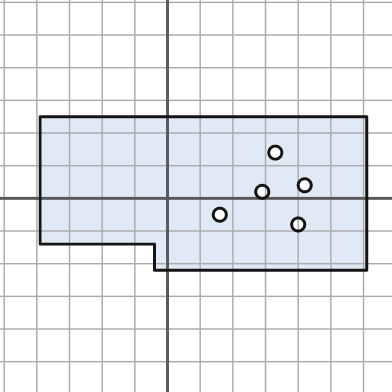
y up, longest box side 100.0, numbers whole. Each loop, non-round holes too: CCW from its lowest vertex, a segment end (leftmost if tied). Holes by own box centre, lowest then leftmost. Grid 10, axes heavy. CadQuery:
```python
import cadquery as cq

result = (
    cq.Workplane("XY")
    .moveTo(-4.0, -22.0)
    .lineTo(61.0, -22.0)
    .lineTo(61.0, 25.0)
    .lineTo(-39.0, 25.0)
    .lineTo(-39.0, -14.0)
    .lineTo(-4.0, -14.0)
    .close()
    .moveTo(40.0, -8.0)
    .circle(2.0)
    .moveTo(16.0, -5.0)
    .circle(2.0)
    .moveTo(29.0, 2.0)
    .circle(2.0)
    .moveTo(42.0, 4.0)
    .circle(2.0)
    .moveTo(33.0, 14.0)
    .circle(2.0)
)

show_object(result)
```